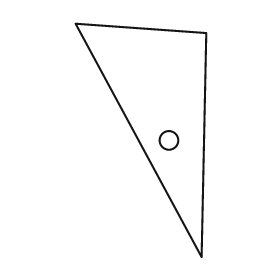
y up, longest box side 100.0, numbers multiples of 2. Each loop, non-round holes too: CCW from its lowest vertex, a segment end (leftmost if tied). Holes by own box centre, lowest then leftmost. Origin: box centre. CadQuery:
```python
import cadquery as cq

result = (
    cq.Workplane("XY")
    .moveTo(26.0, -50.0)
    .lineTo(28.0, 46.0)
    .lineTo(-28.0, 50.0)
    .close()
    .moveTo(12.0, 0.0)
    .circle(4.0)
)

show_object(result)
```